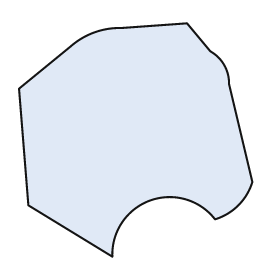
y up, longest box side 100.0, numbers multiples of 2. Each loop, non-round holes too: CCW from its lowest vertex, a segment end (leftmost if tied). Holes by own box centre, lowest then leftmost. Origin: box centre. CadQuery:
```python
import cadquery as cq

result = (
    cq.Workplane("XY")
    .moveTo(-10.0, -50.0)
    .threePointArc((6.0, -26.0), (34.0, -34.0))
    .threePointArc((44.0, -28.0), (50.0, -18.0))
    .lineTo(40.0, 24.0)
    .threePointArc((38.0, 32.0), (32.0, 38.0))
    .lineTo(22.0, 50.0)
    .lineTo(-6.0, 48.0)
    .threePointArc((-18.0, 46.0), (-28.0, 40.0))
    .lineTo(-50.0, 22.0)
    .lineTo(-46.0, -28.0)
    .close()
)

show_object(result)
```